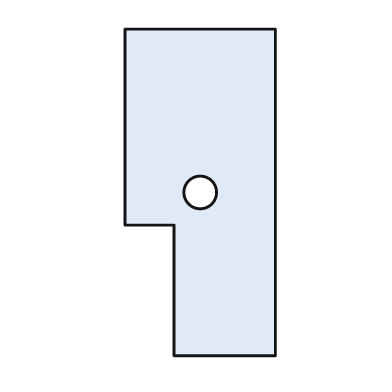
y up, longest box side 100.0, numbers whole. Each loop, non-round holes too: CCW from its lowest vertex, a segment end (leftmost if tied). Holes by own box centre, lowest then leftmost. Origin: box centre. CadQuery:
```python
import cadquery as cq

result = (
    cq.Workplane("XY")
    .moveTo(-8.0, -50.0)
    .lineTo(23.0, -50.0)
    .lineTo(23.0, 50.0)
    .lineTo(-23.0, 50.0)
    .lineTo(-23.0, -10.0)
    .lineTo(-8.0, -10.0)
    .close()
    .moveTo(0.0, 0.0)
    .circle(5.0)
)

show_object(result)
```